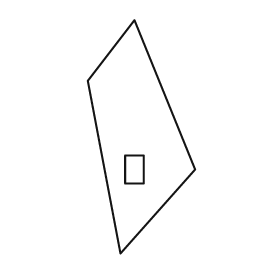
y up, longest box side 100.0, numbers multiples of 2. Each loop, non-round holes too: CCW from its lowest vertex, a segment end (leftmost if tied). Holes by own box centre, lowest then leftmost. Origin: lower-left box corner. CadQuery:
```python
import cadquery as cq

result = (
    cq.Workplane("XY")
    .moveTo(14.0, 0.0)
    .lineTo(46.0, 36.0)
    .lineTo(20.0, 100.0)
    .lineTo(0.0, 74.0)
    .close()
    .moveTo(16.0, 30.0)
    .lineTo(24.0, 30.0)
    .lineTo(24.0, 42.0)
    .lineTo(16.0, 42.0)
    .close()
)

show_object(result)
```